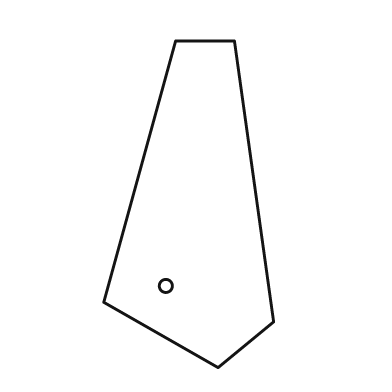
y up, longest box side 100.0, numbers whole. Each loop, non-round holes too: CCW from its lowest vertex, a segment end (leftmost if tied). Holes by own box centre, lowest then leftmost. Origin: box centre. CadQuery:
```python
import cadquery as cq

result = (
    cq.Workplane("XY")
    .moveTo(9.0, -50.0)
    .lineTo(26.0, -36.0)
    .lineTo(14.0, 50.0)
    .lineTo(-4.0, 50.0)
    .lineTo(-26.0, -30.0)
    .close()
    .moveTo(-7.0, -25.0)
    .circle(2.0)
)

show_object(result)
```